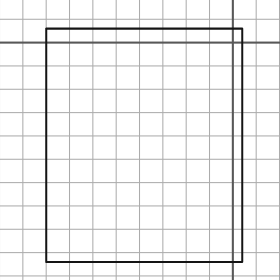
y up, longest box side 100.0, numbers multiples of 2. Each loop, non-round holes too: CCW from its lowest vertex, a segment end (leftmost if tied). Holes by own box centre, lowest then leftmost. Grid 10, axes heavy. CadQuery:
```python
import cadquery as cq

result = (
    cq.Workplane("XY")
    .moveTo(-80.0, -94.0)
    .lineTo(4.0, -94.0)
    .lineTo(4.0, 6.0)
    .lineTo(-80.0, 6.0)
    .close()
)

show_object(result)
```